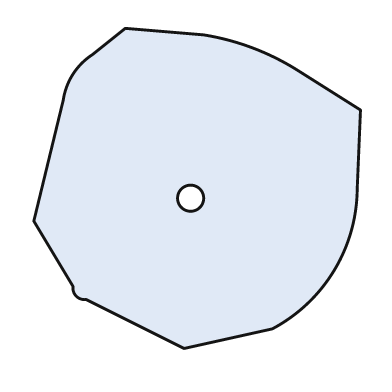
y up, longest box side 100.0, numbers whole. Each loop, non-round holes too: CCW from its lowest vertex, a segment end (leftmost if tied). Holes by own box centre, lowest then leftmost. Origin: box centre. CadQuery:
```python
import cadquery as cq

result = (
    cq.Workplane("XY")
    .moveTo(-4.0, -49.0)
    .lineTo(23.0, -43.0)
    .threePointArc((42.0, -25.0), (49.0, 0.0))
    .lineTo(50.0, 24.0)
    .lineTo(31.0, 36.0)
    .threePointArc((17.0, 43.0), (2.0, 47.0))
    .lineTo(-22.0, 49.0)
    .lineTo(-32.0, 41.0)
    .threePointArc((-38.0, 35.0), (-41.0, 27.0))
    .lineTo(-50.0, -10.0)
    .lineTo(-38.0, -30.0)
    .threePointArc((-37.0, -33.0), (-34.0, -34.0))
    .close()
    .moveTo(-2.0, -3.0)
    .circle(4.0)
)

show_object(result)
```